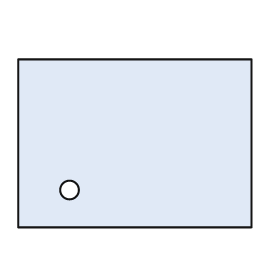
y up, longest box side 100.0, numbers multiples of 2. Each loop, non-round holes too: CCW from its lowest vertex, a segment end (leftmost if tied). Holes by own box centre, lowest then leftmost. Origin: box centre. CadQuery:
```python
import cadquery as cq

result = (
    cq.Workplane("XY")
    .moveTo(-50.0, -36.0)
    .lineTo(50.0, -36.0)
    .lineTo(50.0, 36.0)
    .lineTo(-50.0, 36.0)
    .close()
    .moveTo(-28.0, -20.0)
    .circle(4.0)
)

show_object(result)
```